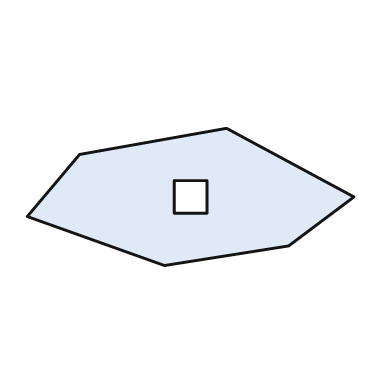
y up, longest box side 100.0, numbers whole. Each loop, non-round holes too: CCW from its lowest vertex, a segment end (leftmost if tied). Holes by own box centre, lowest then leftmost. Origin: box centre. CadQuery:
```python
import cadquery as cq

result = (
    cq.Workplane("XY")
    .moveTo(-8.0, -21.0)
    .lineTo(30.0, -15.0)
    .lineTo(50.0, 0.0)
    .lineTo(11.0, 21.0)
    .lineTo(-34.0, 13.0)
    .lineTo(-50.0, -6.0)
    .close()
    .moveTo(-5.0, -5.0)
    .lineTo(5.0, -5.0)
    .lineTo(5.0, 5.0)
    .lineTo(-5.0, 5.0)
    .close()
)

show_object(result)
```